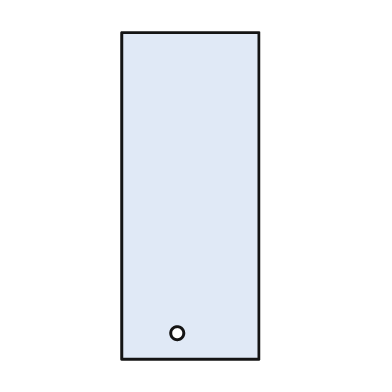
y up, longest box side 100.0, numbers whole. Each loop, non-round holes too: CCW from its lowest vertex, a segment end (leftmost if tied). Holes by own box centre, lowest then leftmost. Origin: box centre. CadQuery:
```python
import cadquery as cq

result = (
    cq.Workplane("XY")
    .moveTo(-21.0, -50.0)
    .lineTo(21.0, -50.0)
    .lineTo(21.0, 50.0)
    .lineTo(-21.0, 50.0)
    .close()
    .moveTo(-4.0, -42.0)
    .circle(2.0)
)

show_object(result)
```